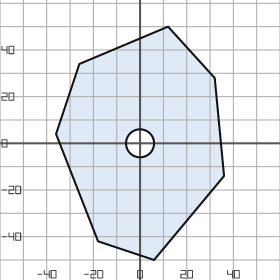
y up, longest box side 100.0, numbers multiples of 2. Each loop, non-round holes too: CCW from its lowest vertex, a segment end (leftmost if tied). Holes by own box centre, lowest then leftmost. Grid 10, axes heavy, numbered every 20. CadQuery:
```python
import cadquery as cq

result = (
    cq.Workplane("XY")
    .moveTo(6.0, -50.0)
    .lineTo(36.0, -14.0)
    .lineTo(32.0, 28.0)
    .lineTo(12.0, 50.0)
    .lineTo(-26.0, 34.0)
    .lineTo(-36.0, 4.0)
    .lineTo(-18.0, -42.0)
    .close()
    .moveTo(0.0, 0.0)
    .circle(6.0)
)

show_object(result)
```